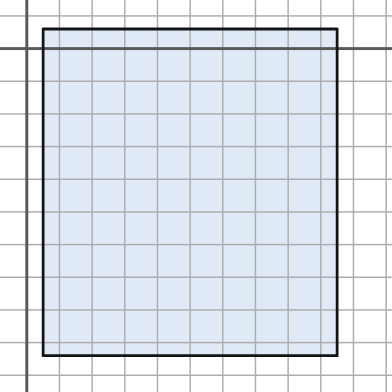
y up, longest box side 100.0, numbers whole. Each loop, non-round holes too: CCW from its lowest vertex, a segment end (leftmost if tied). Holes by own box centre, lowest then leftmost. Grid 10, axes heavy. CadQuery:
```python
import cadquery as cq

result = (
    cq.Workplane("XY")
    .moveTo(5.0, -94.0)
    .lineTo(95.0, -94.0)
    .lineTo(95.0, 6.0)
    .lineTo(5.0, 6.0)
    .close()
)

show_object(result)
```